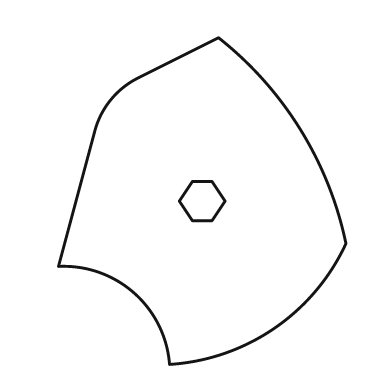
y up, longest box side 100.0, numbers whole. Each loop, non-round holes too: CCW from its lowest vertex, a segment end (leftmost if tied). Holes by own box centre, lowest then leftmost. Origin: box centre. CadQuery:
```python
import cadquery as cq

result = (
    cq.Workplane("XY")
    .moveTo(-10.0, -50.0)
    .threePointArc((22.0, -39.0), (44.0, -13.0))
    .threePointArc((30.0, 22.0), (5.0, 50.0))
    .lineTo(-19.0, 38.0)
    .threePointArc((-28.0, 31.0), (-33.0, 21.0))
    .lineTo(-44.0, -20.0)
    .threePointArc((-21.0, -28.0), (-10.0, -50.0))
    .close()
    .moveTo(-3.0, -6.0)
    .lineTo(3.0, -6.0)
    .lineTo(7.0, 0.0)
    .lineTo(3.0, 6.0)
    .lineTo(-3.0, 6.0)
    .lineTo(-7.0, 0.0)
    .close()
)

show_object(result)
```